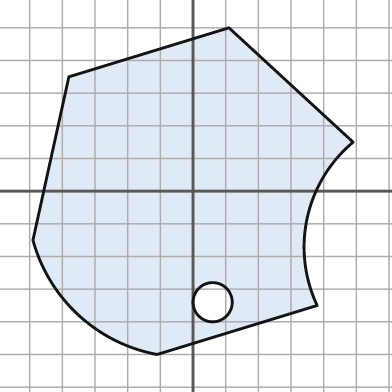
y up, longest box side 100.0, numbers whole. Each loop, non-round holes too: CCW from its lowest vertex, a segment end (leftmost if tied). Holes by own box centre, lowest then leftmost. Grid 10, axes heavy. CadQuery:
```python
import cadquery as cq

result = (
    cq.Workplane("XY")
    .moveTo(-11.0, -50.0)
    .lineTo(38.0, -35.0)
    .threePointArc((35.0, -8.0), (49.0, 15.0))
    .lineTo(11.0, 50.0)
    .lineTo(-38.0, 35.0)
    .lineTo(-49.0, -15.0)
    .threePointArc((-35.0, -38.0), (-11.0, -50.0))
    .close()
    .moveTo(6.0, -34.0)
    .circle(6.0)
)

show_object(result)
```